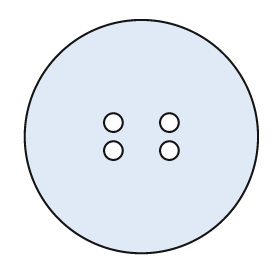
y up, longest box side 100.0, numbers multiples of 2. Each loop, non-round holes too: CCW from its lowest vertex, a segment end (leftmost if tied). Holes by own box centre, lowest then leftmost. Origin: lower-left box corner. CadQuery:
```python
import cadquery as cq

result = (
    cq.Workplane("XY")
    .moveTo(50.0, 50.0)
    .circle(50.0)
    .moveTo(38.0, 44.0)
    .circle(4.0)
    .moveTo(62.0, 44.0)
    .circle(4.0)
    .moveTo(38.0, 56.0)
    .circle(4.0)
    .moveTo(62.0, 56.0)
    .circle(4.0)
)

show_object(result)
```